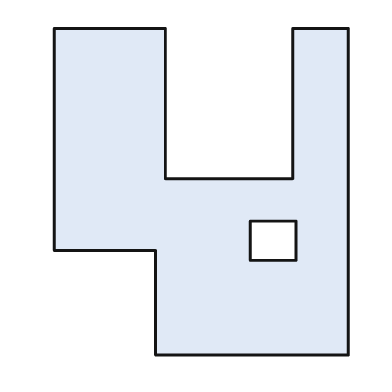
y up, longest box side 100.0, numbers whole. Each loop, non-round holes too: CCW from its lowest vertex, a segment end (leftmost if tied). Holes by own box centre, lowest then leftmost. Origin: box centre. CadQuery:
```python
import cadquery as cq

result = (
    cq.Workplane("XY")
    .moveTo(-14.0, -50.0)
    .lineTo(45.0, -50.0)
    .lineTo(45.0, 50.0)
    .lineTo(28.0, 50.0)
    .lineTo(28.0, 4.0)
    .lineTo(-11.0, 4.0)
    .lineTo(-11.0, 50.0)
    .lineTo(-45.0, 50.0)
    .lineTo(-45.0, -18.0)
    .lineTo(-14.0, -18.0)
    .close()
    .moveTo(15.0, -21.0)
    .lineTo(29.0, -21.0)
    .lineTo(29.0, -9.0)
    .lineTo(15.0, -9.0)
    .close()
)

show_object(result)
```